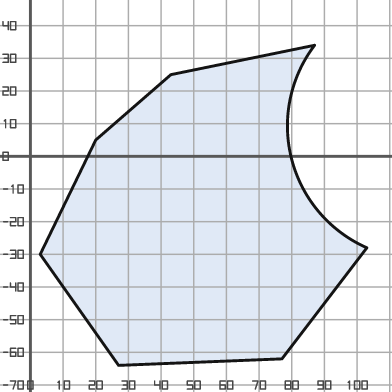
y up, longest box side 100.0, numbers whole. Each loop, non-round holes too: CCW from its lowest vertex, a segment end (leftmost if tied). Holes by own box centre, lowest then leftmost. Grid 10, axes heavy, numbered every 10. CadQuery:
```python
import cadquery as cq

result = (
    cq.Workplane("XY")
    .moveTo(27.0, -64.0)
    .lineTo(77.0, -62.0)
    .lineTo(103.0, -28.0)
    .threePointArc((80.0, -1.0), (87.0, 34.0))
    .lineTo(43.0, 25.0)
    .lineTo(20.0, 5.0)
    .lineTo(3.0, -30.0)
    .close()
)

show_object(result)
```